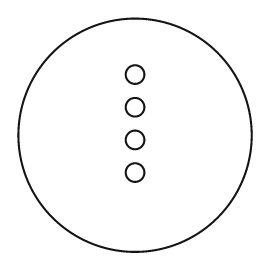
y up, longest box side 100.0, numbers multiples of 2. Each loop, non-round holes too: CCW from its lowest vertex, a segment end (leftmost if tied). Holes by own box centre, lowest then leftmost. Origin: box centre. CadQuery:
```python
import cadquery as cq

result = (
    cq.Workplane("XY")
    .moveTo(0.0, 0.0)
    .circle(50.0)
    .moveTo(0.0, -16.0)
    .circle(4.0)
    .moveTo(0.0, -2.0)
    .circle(4.0)
    .moveTo(0.0, 12.0)
    .circle(4.0)
    .moveTo(0.0, 26.0)
    .circle(4.0)
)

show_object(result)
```